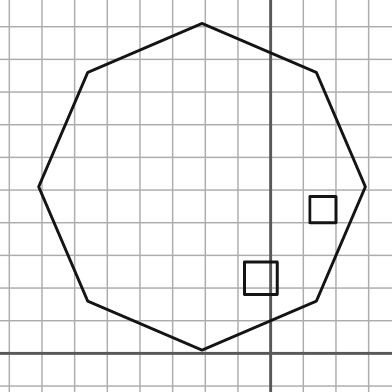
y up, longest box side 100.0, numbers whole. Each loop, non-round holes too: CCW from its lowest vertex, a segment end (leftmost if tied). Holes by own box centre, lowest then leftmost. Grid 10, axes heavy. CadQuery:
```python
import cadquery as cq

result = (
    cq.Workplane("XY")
    .moveTo(-21.0, 1.0)
    .lineTo(14.0, 16.0)
    .lineTo(29.0, 51.0)
    .lineTo(14.0, 86.0)
    .lineTo(-21.0, 101.0)
    .lineTo(-56.0, 86.0)
    .lineTo(-71.0, 51.0)
    .lineTo(-56.0, 16.0)
    .close()
    .moveTo(-8.0, 18.0)
    .lineTo(2.0, 18.0)
    .lineTo(2.0, 28.0)
    .lineTo(-8.0, 28.0)
    .close()
    .moveTo(12.0, 40.0)
    .lineTo(20.0, 40.0)
    .lineTo(20.0, 48.0)
    .lineTo(12.0, 48.0)
    .close()
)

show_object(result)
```